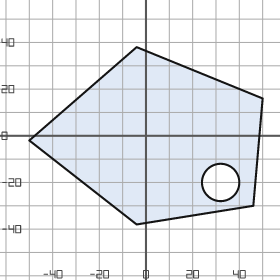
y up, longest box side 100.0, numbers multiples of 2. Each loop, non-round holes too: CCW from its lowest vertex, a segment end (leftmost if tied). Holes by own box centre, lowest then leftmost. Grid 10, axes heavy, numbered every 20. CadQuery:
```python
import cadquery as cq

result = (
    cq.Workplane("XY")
    .moveTo(-4.0, -38.0)
    .lineTo(46.0, -30.0)
    .lineTo(50.0, 16.0)
    .lineTo(-4.0, 38.0)
    .lineTo(-50.0, -2.0)
    .close()
    .moveTo(32.0, -20.0)
    .circle(8.0)
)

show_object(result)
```